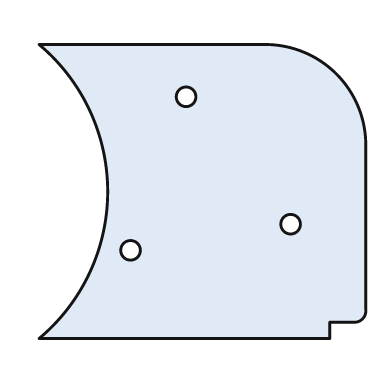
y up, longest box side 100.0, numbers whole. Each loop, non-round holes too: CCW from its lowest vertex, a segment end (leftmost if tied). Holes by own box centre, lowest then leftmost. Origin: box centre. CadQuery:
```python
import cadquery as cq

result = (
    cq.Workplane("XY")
    .moveTo(-50.0, -45.0)
    .lineTo(39.0, -45.0)
    .lineTo(39.0, -40.0)
    .lineTo(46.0, -40.0)
    .threePointArc((49.0, -39.0), (50.0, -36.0))
    .lineTo(50.0, 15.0)
    .threePointArc((41.0, 36.0), (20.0, 45.0))
    .lineTo(-50.0, 45.0)
    .threePointArc((-29.0, 0.0), (-50.0, -45.0))
    .close()
    .moveTo(-22.0, -18.0)
    .circle(3.0)
    .moveTo(27.0, -10.0)
    .circle(3.0)
    .moveTo(-5.0, 29.0)
    .circle(3.0)
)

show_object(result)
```